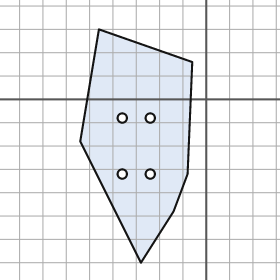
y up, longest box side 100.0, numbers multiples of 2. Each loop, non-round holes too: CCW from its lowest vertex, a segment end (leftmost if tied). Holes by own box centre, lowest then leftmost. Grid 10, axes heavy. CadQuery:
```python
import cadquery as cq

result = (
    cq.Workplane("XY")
    .moveTo(-28.0, -70.0)
    .lineTo(-14.0, -48.0)
    .lineTo(-8.0, -32.0)
    .lineTo(-6.0, 16.0)
    .lineTo(-46.0, 30.0)
    .lineTo(-54.0, -18.0)
    .close()
    .moveTo(-36.0, -32.0)
    .circle(2.0)
    .moveTo(-24.0, -32.0)
    .circle(2.0)
    .moveTo(-36.0, -8.0)
    .circle(2.0)
    .moveTo(-24.0, -8.0)
    .circle(2.0)
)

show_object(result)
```